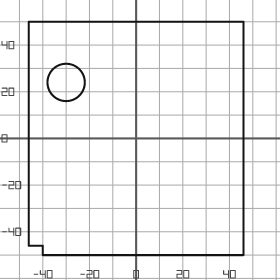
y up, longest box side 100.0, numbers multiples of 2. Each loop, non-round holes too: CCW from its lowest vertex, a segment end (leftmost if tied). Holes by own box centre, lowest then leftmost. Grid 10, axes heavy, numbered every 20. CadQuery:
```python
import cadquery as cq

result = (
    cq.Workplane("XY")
    .moveTo(-40.0, -50.0)
    .lineTo(46.0, -50.0)
    .lineTo(46.0, 50.0)
    .lineTo(-46.0, 50.0)
    .lineTo(-46.0, -46.0)
    .lineTo(-40.0, -46.0)
    .close()
    .moveTo(-30.0, 24.0)
    .circle(8.0)
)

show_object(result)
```